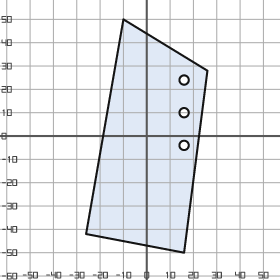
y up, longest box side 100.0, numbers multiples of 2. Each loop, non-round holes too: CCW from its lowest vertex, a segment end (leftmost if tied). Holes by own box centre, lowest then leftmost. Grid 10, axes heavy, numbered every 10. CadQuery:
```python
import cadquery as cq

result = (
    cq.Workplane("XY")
    .moveTo(16.0, -50.0)
    .lineTo(26.0, 28.0)
    .lineTo(-10.0, 50.0)
    .lineTo(-26.0, -42.0)
    .close()
    .moveTo(16.0, -4.0)
    .circle(2.0)
    .moveTo(16.0, 10.0)
    .circle(2.0)
    .moveTo(16.0, 24.0)
    .circle(2.0)
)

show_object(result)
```